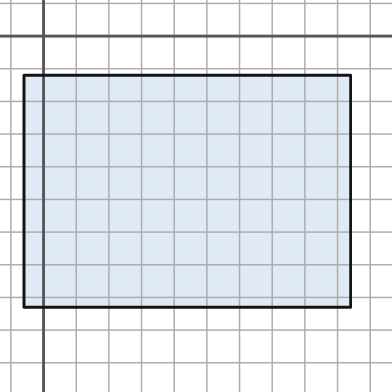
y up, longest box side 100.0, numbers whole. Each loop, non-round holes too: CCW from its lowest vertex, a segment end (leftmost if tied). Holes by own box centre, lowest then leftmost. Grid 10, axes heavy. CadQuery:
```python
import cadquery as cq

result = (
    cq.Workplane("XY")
    .moveTo(-6.0, -83.0)
    .lineTo(94.0, -83.0)
    .lineTo(94.0, -12.0)
    .lineTo(-6.0, -12.0)
    .close()
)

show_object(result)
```